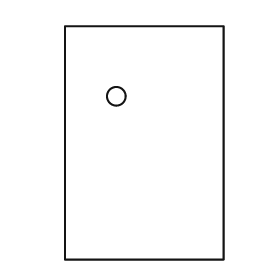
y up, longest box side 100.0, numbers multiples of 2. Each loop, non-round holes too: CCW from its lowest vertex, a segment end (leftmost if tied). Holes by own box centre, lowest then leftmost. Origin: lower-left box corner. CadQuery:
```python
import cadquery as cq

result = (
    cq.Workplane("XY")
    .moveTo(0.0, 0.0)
    .lineTo(68.0, 0.0)
    .lineTo(68.0, 100.0)
    .lineTo(0.0, 100.0)
    .close()
    .moveTo(22.0, 70.0)
    .circle(4.0)
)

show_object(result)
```